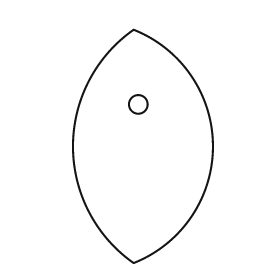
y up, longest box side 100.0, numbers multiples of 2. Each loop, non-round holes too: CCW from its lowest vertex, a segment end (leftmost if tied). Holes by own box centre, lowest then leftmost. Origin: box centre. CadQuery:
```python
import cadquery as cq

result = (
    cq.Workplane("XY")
    .moveTo(-4.0, -50.0)
    .threePointArc((30.0, 0.0), (-4.0, 50.0))
    .threePointArc((-30.0, 0.0), (-4.0, -50.0))
    .close()
    .moveTo(-2.0, 18.0)
    .circle(4.0)
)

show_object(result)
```